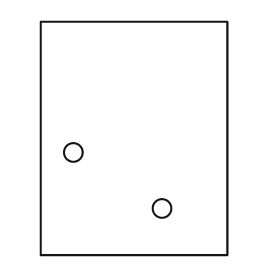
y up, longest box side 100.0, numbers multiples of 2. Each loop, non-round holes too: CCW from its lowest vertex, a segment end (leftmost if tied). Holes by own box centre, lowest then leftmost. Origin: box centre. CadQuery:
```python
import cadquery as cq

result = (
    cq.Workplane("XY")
    .moveTo(-40.0, -50.0)
    .lineTo(40.0, -50.0)
    .lineTo(40.0, 50.0)
    .lineTo(-40.0, 50.0)
    .close()
    .moveTo(12.0, -30.0)
    .circle(4.0)
    .moveTo(-26.0, -6.0)
    .circle(4.0)
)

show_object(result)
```